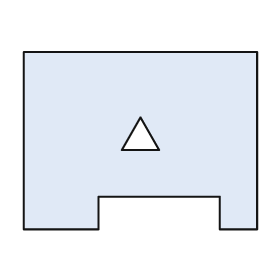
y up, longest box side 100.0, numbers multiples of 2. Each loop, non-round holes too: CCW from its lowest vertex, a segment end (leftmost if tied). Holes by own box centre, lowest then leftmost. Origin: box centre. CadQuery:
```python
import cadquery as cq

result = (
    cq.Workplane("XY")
    .moveTo(-50.0, -38.0)
    .lineTo(-18.0, -38.0)
    .lineTo(-18.0, -24.0)
    .lineTo(34.0, -24.0)
    .lineTo(34.0, -38.0)
    .lineTo(50.0, -38.0)
    .lineTo(50.0, 38.0)
    .lineTo(-50.0, 38.0)
    .close()
    .moveTo(-8.0, -4.0)
    .lineTo(8.0, -4.0)
    .lineTo(0.0, 10.0)
    .close()
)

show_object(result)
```